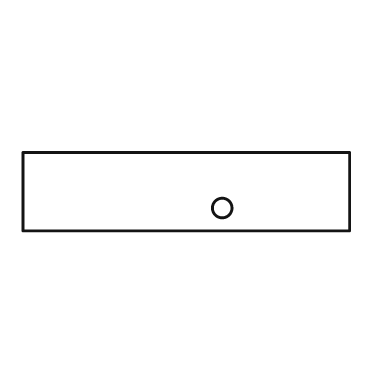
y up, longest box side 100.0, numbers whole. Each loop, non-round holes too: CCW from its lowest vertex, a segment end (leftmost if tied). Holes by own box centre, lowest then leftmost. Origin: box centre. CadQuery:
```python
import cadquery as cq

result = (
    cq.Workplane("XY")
    .moveTo(-50.0, -12.0)
    .lineTo(50.0, -12.0)
    .lineTo(50.0, 12.0)
    .lineTo(-50.0, 12.0)
    .close()
    .moveTo(11.0, -5.0)
    .circle(3.0)
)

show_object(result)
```